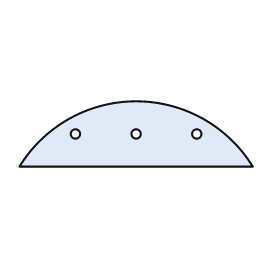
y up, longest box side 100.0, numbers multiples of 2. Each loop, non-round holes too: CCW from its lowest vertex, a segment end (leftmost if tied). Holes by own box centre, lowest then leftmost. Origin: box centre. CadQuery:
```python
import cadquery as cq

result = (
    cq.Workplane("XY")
    .moveTo(-50.0, -14.0)
    .lineTo(50.0, -14.0)
    .threePointArc((0.0, 14.0), (-50.0, -14.0))
    .close()
    .moveTo(-26.0, 0.0)
    .circle(2.0)
    .moveTo(0.0, 0.0)
    .circle(2.0)
    .moveTo(26.0, 0.0)
    .circle(2.0)
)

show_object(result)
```